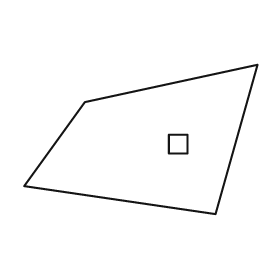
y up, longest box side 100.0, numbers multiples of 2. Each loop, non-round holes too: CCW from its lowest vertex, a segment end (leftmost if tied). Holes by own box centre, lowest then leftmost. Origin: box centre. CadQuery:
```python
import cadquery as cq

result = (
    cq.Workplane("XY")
    .moveTo(32.0, -32.0)
    .lineTo(50.0, 32.0)
    .lineTo(-24.0, 16.0)
    .lineTo(-50.0, -20.0)
    .close()
    .moveTo(12.0, -6.0)
    .lineTo(20.0, -6.0)
    .lineTo(20.0, 2.0)
    .lineTo(12.0, 2.0)
    .close()
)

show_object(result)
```